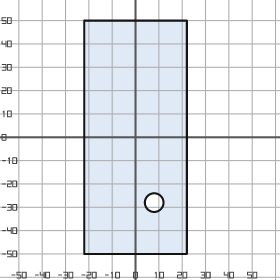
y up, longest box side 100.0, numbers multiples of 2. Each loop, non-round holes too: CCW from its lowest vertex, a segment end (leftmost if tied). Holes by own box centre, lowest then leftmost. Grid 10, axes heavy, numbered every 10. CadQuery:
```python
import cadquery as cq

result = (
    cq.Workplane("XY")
    .moveTo(-22.0, -50.0)
    .lineTo(22.0, -50.0)
    .lineTo(22.0, 50.0)
    .lineTo(-22.0, 50.0)
    .close()
    .moveTo(8.0, -28.0)
    .circle(4.0)
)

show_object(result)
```